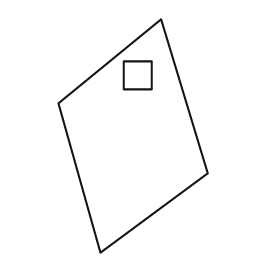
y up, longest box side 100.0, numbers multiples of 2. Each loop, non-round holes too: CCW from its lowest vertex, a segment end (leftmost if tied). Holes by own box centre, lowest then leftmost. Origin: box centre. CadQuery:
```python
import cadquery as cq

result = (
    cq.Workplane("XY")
    .moveTo(-14.0, -50.0)
    .lineTo(32.0, -16.0)
    .lineTo(12.0, 50.0)
    .lineTo(-32.0, 14.0)
    .close()
    .moveTo(-4.0, 20.0)
    .lineTo(8.0, 20.0)
    .lineTo(8.0, 32.0)
    .lineTo(-4.0, 32.0)
    .close()
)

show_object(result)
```